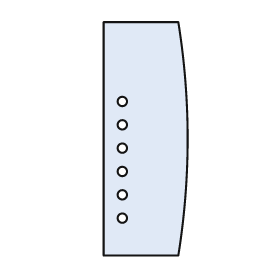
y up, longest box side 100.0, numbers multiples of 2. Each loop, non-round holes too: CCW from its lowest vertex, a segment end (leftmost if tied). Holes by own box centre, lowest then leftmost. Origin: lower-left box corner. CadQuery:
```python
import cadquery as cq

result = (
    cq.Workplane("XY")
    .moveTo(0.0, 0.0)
    .lineTo(32.0, 0.0)
    .threePointArc((36.0, 50.0), (32.0, 100.0))
    .lineTo(0.0, 100.0)
    .close()
    .moveTo(8.0, 16.0)
    .circle(2.0)
    .moveTo(8.0, 26.0)
    .circle(2.0)
    .moveTo(8.0, 36.0)
    .circle(2.0)
    .moveTo(8.0, 46.0)
    .circle(2.0)
    .moveTo(8.0, 56.0)
    .circle(2.0)
    .moveTo(8.0, 66.0)
    .circle(2.0)
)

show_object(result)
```